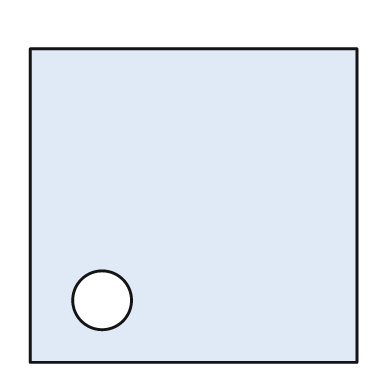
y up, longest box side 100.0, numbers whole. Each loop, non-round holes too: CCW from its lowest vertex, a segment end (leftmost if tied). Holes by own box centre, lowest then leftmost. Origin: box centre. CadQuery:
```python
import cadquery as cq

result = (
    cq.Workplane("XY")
    .moveTo(-50.0, -48.0)
    .lineTo(50.0, -48.0)
    .lineTo(50.0, 48.0)
    .lineTo(-50.0, 48.0)
    .close()
    .moveTo(-28.0, -29.0)
    .circle(9.0)
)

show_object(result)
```